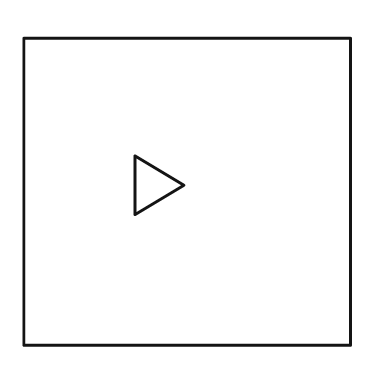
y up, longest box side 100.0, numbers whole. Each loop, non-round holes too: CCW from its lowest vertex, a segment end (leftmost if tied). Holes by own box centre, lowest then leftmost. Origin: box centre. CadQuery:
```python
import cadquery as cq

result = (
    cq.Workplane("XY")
    .moveTo(-50.0, -47.0)
    .lineTo(50.0, -47.0)
    .lineTo(50.0, 47.0)
    .lineTo(-50.0, 47.0)
    .close()
    .moveTo(-16.0, -7.0)
    .lineTo(-1.0, 2.0)
    .lineTo(-16.0, 11.0)
    .close()
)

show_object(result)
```